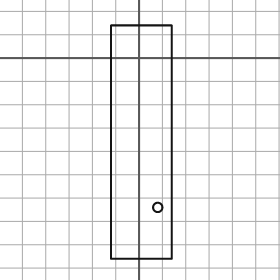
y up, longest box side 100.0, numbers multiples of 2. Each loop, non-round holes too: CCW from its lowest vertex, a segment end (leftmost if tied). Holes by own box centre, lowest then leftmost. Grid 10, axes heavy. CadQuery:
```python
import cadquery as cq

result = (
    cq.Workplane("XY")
    .moveTo(-12.0, -86.0)
    .lineTo(14.0, -86.0)
    .lineTo(14.0, 14.0)
    .lineTo(-12.0, 14.0)
    .close()
    .moveTo(8.0, -64.0)
    .circle(2.0)
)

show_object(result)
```